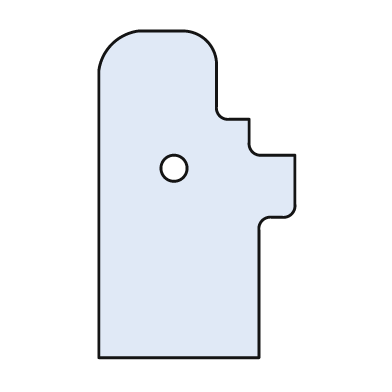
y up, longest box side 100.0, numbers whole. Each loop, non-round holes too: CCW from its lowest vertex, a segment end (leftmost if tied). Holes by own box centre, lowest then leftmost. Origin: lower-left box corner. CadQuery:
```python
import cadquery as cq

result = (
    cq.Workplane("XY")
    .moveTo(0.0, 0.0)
    .lineTo(49.0, 0.0)
    .lineTo(49.0, 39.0)
    .threePointArc((50.0, 42.0), (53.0, 43.0))
    .lineTo(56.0, 43.0)
    .threePointArc((59.0, 44.0), (60.0, 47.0))
    .lineTo(60.0, 62.0)
    .lineTo(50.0, 62.0)
    .threePointArc((47.0, 63.0), (46.0, 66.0))
    .lineTo(46.0, 73.0)
    .lineTo(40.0, 73.0)
    .threePointArc((37.0, 74.0), (36.0, 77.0))
    .lineTo(36.0, 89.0)
    .threePointArc((33.0, 97.0), (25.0, 100.0))
    .lineTo(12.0, 100.0)
    .threePointArc((4.0, 96.0), (0.0, 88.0))
    .close()
    .moveTo(23.0, 58.0)
    .circle(4.0)
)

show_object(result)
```